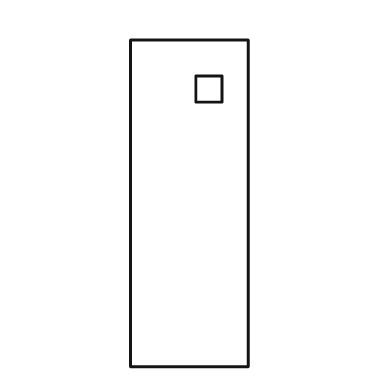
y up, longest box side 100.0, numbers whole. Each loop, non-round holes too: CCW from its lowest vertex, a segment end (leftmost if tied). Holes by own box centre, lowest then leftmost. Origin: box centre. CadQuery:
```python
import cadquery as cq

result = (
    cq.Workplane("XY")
    .moveTo(-18.0, -50.0)
    .lineTo(18.0, -50.0)
    .lineTo(18.0, 50.0)
    .lineTo(-18.0, 50.0)
    .close()
    .moveTo(2.0, 31.0)
    .lineTo(10.0, 31.0)
    .lineTo(10.0, 39.0)
    .lineTo(2.0, 39.0)
    .close()
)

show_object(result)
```